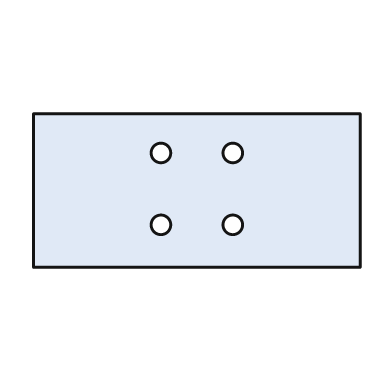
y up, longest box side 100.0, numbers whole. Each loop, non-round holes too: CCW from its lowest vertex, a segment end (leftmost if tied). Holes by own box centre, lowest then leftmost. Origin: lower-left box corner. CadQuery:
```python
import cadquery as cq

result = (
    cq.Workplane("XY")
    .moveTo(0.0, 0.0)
    .lineTo(100.0, 0.0)
    .lineTo(100.0, 47.0)
    .lineTo(0.0, 47.0)
    .close()
    .moveTo(39.0, 13.0)
    .circle(3.0)
    .moveTo(61.0, 13.0)
    .circle(3.0)
    .moveTo(39.0, 35.0)
    .circle(3.0)
    .moveTo(61.0, 35.0)
    .circle(3.0)
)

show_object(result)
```